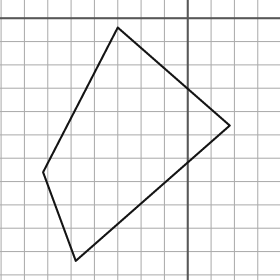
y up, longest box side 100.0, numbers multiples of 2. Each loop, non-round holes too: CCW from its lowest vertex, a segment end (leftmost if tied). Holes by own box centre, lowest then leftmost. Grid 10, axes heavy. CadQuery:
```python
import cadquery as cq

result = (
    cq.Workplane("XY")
    .moveTo(-48.0, -104.0)
    .lineTo(18.0, -46.0)
    .lineTo(-30.0, -4.0)
    .lineTo(-62.0, -66.0)
    .close()
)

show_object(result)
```